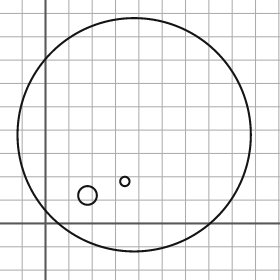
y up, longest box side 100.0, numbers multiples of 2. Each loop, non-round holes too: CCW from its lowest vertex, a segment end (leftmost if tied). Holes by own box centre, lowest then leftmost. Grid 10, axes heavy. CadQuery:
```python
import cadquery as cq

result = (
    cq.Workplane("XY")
    .moveTo(38.0, 38.0)
    .circle(50.0)
    .moveTo(18.0, 12.0)
    .circle(4.0)
    .moveTo(34.0, 18.0)
    .circle(2.0)
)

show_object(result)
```